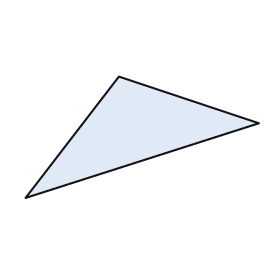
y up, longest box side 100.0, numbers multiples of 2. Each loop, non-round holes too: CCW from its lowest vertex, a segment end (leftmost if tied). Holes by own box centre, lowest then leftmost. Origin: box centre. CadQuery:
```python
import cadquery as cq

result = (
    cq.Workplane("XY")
    .moveTo(-50.0, -26.0)
    .lineTo(50.0, 6.0)
    .lineTo(-10.0, 26.0)
    .close()
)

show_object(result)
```